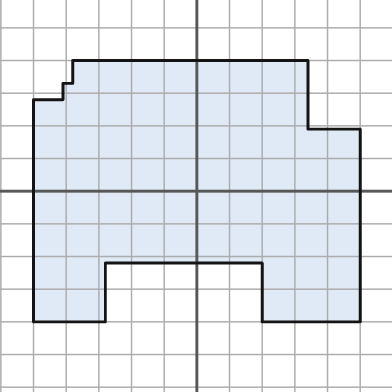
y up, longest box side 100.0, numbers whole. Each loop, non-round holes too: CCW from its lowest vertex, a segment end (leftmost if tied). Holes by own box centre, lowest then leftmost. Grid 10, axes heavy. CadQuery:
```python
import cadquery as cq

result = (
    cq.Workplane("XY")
    .moveTo(-50.0, -40.0)
    .lineTo(-28.0, -40.0)
    .lineTo(-28.0, -22.0)
    .lineTo(20.0, -22.0)
    .lineTo(20.0, -40.0)
    .lineTo(50.0, -40.0)
    .lineTo(50.0, 19.0)
    .lineTo(34.0, 19.0)
    .lineTo(34.0, 40.0)
    .lineTo(-38.0, 40.0)
    .lineTo(-38.0, 33.0)
    .lineTo(-41.0, 33.0)
    .lineTo(-41.0, 28.0)
    .lineTo(-50.0, 28.0)
    .close()
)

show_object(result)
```